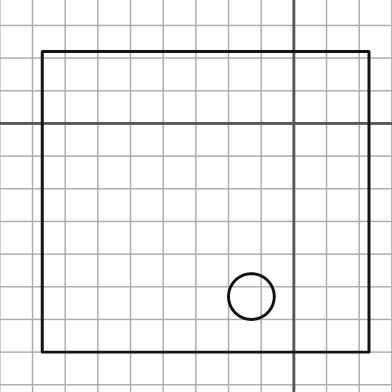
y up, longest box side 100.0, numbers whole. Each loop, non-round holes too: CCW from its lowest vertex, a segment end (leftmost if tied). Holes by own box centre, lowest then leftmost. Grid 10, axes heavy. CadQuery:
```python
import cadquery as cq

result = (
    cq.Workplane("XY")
    .moveTo(-77.0, -70.0)
    .lineTo(23.0, -70.0)
    .lineTo(23.0, 22.0)
    .lineTo(-77.0, 22.0)
    .close()
    .moveTo(-13.0, -53.0)
    .circle(7.0)
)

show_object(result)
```